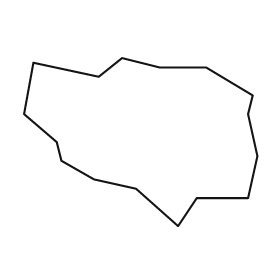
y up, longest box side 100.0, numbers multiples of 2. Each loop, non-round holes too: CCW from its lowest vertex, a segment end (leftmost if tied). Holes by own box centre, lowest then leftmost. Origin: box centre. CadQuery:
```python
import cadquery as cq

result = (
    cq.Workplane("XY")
    .moveTo(16.0, -36.0)
    .lineTo(24.0, -24.0)
    .lineTo(46.0, -24.0)
    .lineTo(50.0, -6.0)
    .lineTo(46.0, 12.0)
    .lineTo(48.0, 20.0)
    .lineTo(28.0, 32.0)
    .lineTo(8.0, 32.0)
    .lineTo(-8.0, 36.0)
    .lineTo(-18.0, 28.0)
    .lineTo(-46.0, 34.0)
    .lineTo(-50.0, 12.0)
    .lineTo(-36.0, 0.0)
    .lineTo(-34.0, -8.0)
    .lineTo(-20.0, -16.0)
    .lineTo(-2.0, -20.0)
    .close()
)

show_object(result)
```